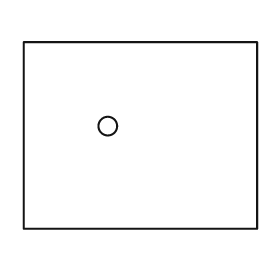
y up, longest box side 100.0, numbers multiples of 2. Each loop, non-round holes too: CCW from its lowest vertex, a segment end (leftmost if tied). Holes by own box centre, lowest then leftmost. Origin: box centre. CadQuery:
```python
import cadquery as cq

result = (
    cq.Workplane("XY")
    .moveTo(-50.0, -40.0)
    .lineTo(50.0, -40.0)
    .lineTo(50.0, 40.0)
    .lineTo(-50.0, 40.0)
    .close()
    .moveTo(-14.0, 4.0)
    .circle(4.0)
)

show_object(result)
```